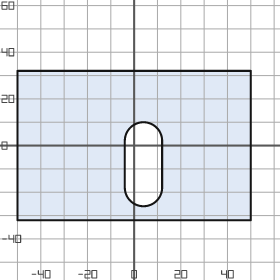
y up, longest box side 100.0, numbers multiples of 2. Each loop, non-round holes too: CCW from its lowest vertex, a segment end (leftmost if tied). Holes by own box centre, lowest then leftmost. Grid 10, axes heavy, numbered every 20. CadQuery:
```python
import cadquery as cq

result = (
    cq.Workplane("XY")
    .moveTo(-50.0, -32.0)
    .lineTo(50.0, -32.0)
    .lineTo(50.0, 32.0)
    .lineTo(-50.0, 32.0)
    .close()
    .moveTo(-4.0, -18.0)
    .threePointArc((4.0, -26.0), (12.0, -18.0))
    .lineTo(12.0, 2.0)
    .threePointArc((4.0, 10.0), (-4.0, 2.0))
    .close()
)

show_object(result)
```